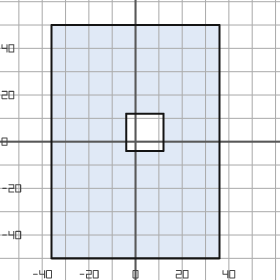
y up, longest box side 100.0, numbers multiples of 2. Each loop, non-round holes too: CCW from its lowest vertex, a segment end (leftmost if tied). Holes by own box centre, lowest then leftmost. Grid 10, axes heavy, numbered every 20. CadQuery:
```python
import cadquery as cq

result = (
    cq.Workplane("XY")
    .moveTo(-36.0, -50.0)
    .lineTo(36.0, -50.0)
    .lineTo(36.0, 50.0)
    .lineTo(-36.0, 50.0)
    .close()
    .moveTo(-4.0, -4.0)
    .lineTo(12.0, -4.0)
    .lineTo(12.0, 12.0)
    .lineTo(-4.0, 12.0)
    .close()
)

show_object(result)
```